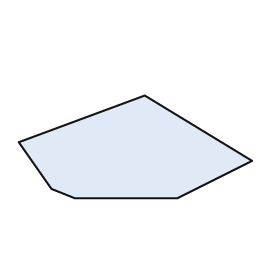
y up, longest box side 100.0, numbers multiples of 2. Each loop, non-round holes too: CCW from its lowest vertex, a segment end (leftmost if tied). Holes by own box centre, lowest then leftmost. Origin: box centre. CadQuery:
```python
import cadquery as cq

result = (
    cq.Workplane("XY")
    .moveTo(-26.0, -22.0)
    .lineTo(18.0, -22.0)
    .lineTo(50.0, -6.0)
    .lineTo(4.0, 22.0)
    .lineTo(-50.0, 2.0)
    .lineTo(-36.0, -18.0)
    .close()
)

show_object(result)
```